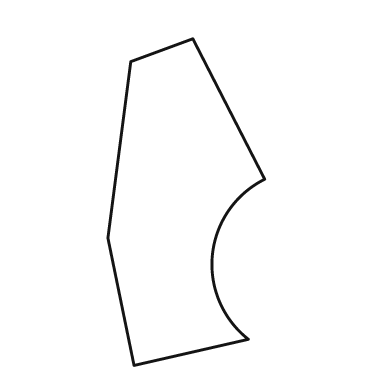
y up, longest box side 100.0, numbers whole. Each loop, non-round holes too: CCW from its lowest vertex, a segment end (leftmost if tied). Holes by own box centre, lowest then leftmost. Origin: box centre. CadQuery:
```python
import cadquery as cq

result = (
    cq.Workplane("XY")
    .moveTo(-16.0, -50.0)
    .lineTo(19.0, -42.0)
    .threePointArc((8.0, -16.0), (24.0, 7.0))
    .lineTo(2.0, 50.0)
    .lineTo(-17.0, 43.0)
    .lineTo(-24.0, -11.0)
    .close()
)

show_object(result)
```